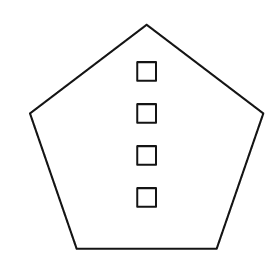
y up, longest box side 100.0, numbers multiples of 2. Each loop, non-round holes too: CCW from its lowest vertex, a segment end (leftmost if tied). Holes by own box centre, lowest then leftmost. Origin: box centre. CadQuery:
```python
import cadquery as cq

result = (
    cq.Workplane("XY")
    .moveTo(-30.0, -48.0)
    .lineTo(30.0, -48.0)
    .lineTo(50.0, 10.0)
    .lineTo(0.0, 48.0)
    .lineTo(-50.0, 10.0)
    .close()
    .moveTo(-4.0, -30.0)
    .lineTo(4.0, -30.0)
    .lineTo(4.0, -22.0)
    .lineTo(-4.0, -22.0)
    .close()
    .moveTo(-4.0, -12.0)
    .lineTo(4.0, -12.0)
    .lineTo(4.0, -4.0)
    .lineTo(-4.0, -4.0)
    .close()
    .moveTo(-4.0, 6.0)
    .lineTo(4.0, 6.0)
    .lineTo(4.0, 14.0)
    .lineTo(-4.0, 14.0)
    .close()
    .moveTo(-4.0, 24.0)
    .lineTo(4.0, 24.0)
    .lineTo(4.0, 32.0)
    .lineTo(-4.0, 32.0)
    .close()
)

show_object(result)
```